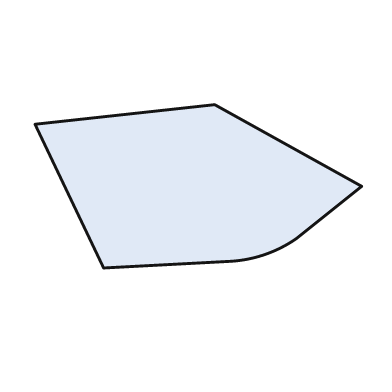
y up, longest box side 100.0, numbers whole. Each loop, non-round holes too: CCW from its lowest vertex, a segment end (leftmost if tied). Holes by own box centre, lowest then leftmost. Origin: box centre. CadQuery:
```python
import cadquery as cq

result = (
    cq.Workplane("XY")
    .moveTo(-29.0, -25.0)
    .lineTo(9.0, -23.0)
    .threePointArc((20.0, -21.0), (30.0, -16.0))
    .lineTo(50.0, 0.0)
    .lineTo(5.0, 25.0)
    .lineTo(-50.0, 19.0)
    .close()
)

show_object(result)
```